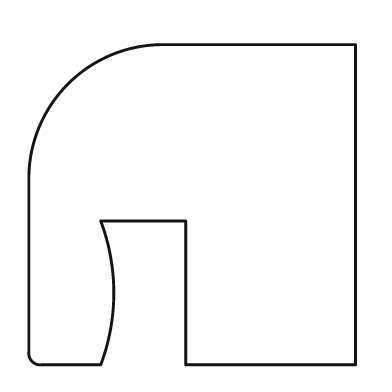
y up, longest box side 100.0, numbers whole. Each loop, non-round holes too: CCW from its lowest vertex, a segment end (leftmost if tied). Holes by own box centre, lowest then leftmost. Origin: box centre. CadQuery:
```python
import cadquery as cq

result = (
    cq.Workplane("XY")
    .moveTo(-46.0, -49.0)
    .lineTo(-28.0, -49.0)
    .threePointArc((-24.0, -27.0), (-28.0, -5.0))
    .lineTo(-2.0, -5.0)
    .lineTo(-2.0, -49.0)
    .lineTo(50.0, -49.0)
    .lineTo(50.0, 49.0)
    .lineTo(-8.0, 49.0)
    .threePointArc((-38.0, 37.0), (-50.0, 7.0))
    .lineTo(-50.0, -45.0)
    .threePointArc((-49.0, -48.0), (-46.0, -49.0))
    .close()
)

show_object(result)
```